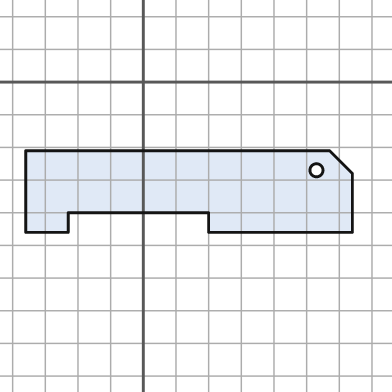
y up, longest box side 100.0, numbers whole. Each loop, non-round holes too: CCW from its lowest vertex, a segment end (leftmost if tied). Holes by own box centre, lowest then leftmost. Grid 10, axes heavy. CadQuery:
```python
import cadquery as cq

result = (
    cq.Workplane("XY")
    .moveTo(-36.0, -46.0)
    .lineTo(-23.0, -46.0)
    .lineTo(-23.0, -40.0)
    .lineTo(20.0, -40.0)
    .lineTo(20.0, -46.0)
    .lineTo(64.0, -46.0)
    .lineTo(64.0, -28.0)
    .lineTo(57.0, -21.0)
    .lineTo(-36.0, -21.0)
    .close()
    .moveTo(53.0, -27.0)
    .circle(2.0)
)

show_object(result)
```